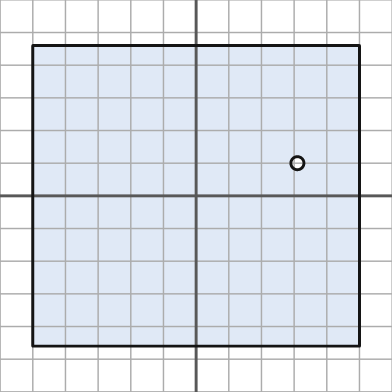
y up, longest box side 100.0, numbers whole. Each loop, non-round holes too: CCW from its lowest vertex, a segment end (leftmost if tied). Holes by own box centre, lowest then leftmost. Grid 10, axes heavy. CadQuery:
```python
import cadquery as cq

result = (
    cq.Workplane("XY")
    .moveTo(-50.0, -46.0)
    .lineTo(50.0, -46.0)
    .lineTo(50.0, 46.0)
    .lineTo(-50.0, 46.0)
    .close()
    .moveTo(31.0, 10.0)
    .circle(2.0)
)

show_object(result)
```